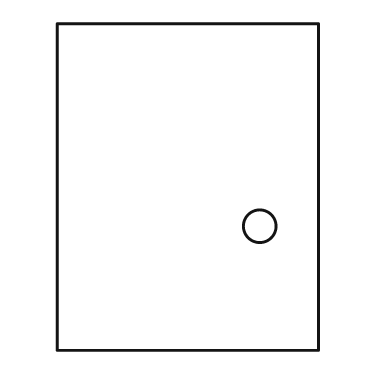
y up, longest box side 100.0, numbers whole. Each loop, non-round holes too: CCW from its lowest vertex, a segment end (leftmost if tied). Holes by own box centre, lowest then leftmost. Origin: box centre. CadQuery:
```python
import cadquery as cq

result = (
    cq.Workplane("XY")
    .moveTo(-40.0, -50.0)
    .lineTo(40.0, -50.0)
    .lineTo(40.0, 50.0)
    .lineTo(-40.0, 50.0)
    .close()
    .moveTo(22.0, -12.0)
    .circle(5.0)
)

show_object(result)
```